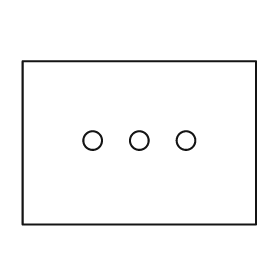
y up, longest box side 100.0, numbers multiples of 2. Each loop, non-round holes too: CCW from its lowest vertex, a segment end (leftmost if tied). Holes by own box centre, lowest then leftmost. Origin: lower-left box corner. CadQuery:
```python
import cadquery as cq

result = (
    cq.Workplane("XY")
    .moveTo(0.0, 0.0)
    .lineTo(100.0, 0.0)
    .lineTo(100.0, 70.0)
    .lineTo(0.0, 70.0)
    .close()
    .moveTo(30.0, 36.0)
    .circle(4.0)
    .moveTo(50.0, 36.0)
    .circle(4.0)
    .moveTo(70.0, 36.0)
    .circle(4.0)
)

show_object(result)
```